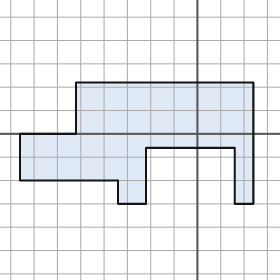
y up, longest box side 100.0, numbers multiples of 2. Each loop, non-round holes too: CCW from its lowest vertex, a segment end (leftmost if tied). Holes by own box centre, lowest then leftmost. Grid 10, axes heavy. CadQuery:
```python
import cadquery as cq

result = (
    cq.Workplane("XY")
    .moveTo(-34.0, -30.0)
    .lineTo(-22.0, -30.0)
    .lineTo(-22.0, -6.0)
    .lineTo(16.0, -6.0)
    .lineTo(16.0, -30.0)
    .lineTo(24.0, -30.0)
    .lineTo(24.0, 22.0)
    .lineTo(-52.0, 22.0)
    .lineTo(-52.0, 0.0)
    .lineTo(-76.0, 0.0)
    .lineTo(-76.0, -20.0)
    .lineTo(-34.0, -20.0)
    .close()
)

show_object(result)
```